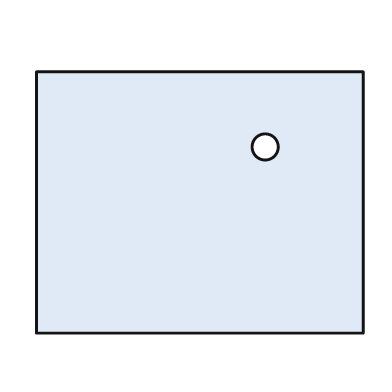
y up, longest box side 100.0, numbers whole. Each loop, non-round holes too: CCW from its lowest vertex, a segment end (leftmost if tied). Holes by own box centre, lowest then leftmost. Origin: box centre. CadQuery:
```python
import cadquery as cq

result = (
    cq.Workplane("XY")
    .moveTo(-50.0, -40.0)
    .lineTo(50.0, -40.0)
    .lineTo(50.0, 40.0)
    .lineTo(-50.0, 40.0)
    .close()
    .moveTo(20.0, 17.0)
    .circle(4.0)
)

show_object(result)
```